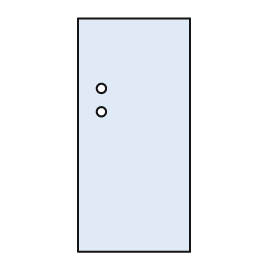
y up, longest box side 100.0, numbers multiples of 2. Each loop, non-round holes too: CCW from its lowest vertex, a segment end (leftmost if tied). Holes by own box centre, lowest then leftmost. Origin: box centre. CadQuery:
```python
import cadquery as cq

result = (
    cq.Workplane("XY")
    .moveTo(-24.0, -50.0)
    .lineTo(24.0, -50.0)
    .lineTo(24.0, 50.0)
    .lineTo(-24.0, 50.0)
    .close()
    .moveTo(-14.0, 10.0)
    .circle(2.0)
    .moveTo(-14.0, 20.0)
    .circle(2.0)
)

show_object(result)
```